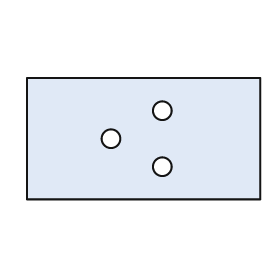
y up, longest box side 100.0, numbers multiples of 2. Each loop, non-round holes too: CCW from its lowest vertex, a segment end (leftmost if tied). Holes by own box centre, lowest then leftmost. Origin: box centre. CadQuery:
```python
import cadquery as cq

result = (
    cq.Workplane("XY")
    .moveTo(-50.0, -26.0)
    .lineTo(50.0, -26.0)
    .lineTo(50.0, 26.0)
    .lineTo(-50.0, 26.0)
    .close()
    .moveTo(8.0, -12.0)
    .circle(4.0)
    .moveTo(-14.0, 0.0)
    .circle(4.0)
    .moveTo(8.0, 12.0)
    .circle(4.0)
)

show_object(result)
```